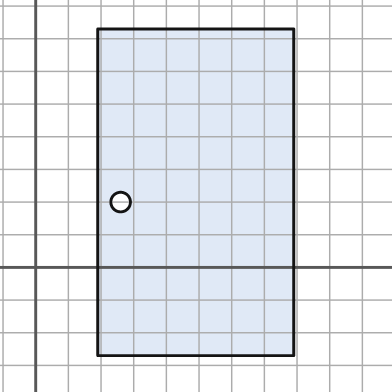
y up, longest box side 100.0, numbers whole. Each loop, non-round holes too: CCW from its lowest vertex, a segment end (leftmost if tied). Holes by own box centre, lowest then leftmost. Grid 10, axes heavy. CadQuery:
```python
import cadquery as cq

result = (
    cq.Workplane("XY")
    .moveTo(19.0, -27.0)
    .lineTo(79.0, -27.0)
    .lineTo(79.0, 73.0)
    .lineTo(19.0, 73.0)
    .close()
    .moveTo(26.0, 20.0)
    .circle(3.0)
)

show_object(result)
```